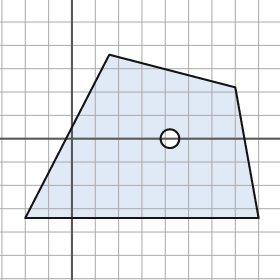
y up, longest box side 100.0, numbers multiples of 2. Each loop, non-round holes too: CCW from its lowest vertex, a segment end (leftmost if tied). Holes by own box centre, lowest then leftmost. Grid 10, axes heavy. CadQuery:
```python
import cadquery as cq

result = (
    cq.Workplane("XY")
    .moveTo(-20.0, -34.0)
    .lineTo(80.0, -34.0)
    .lineTo(70.0, 22.0)
    .lineTo(16.0, 36.0)
    .close()
    .moveTo(42.0, 0.0)
    .circle(4.0)
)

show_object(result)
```